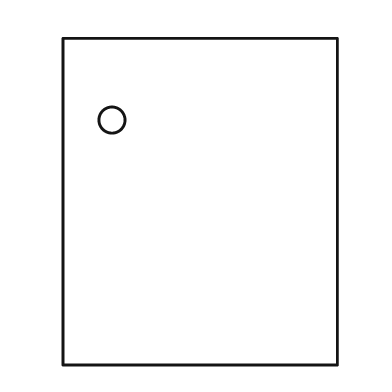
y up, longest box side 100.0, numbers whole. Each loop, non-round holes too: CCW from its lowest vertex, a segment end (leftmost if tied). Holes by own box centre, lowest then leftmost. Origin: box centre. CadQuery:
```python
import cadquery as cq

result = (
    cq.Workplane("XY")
    .moveTo(-42.0, -50.0)
    .lineTo(42.0, -50.0)
    .lineTo(42.0, 50.0)
    .lineTo(-42.0, 50.0)
    .close()
    .moveTo(-27.0, 25.0)
    .circle(4.0)
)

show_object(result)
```